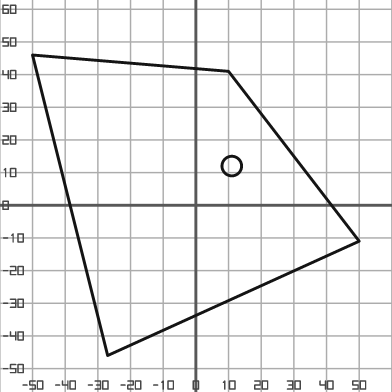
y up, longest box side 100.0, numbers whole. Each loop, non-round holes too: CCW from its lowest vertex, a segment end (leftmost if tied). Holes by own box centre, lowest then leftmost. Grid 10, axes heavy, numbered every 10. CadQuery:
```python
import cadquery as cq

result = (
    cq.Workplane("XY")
    .moveTo(-27.0, -46.0)
    .lineTo(50.0, -11.0)
    .lineTo(10.0, 41.0)
    .lineTo(-50.0, 46.0)
    .close()
    .moveTo(11.0, 12.0)
    .circle(3.0)
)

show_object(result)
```